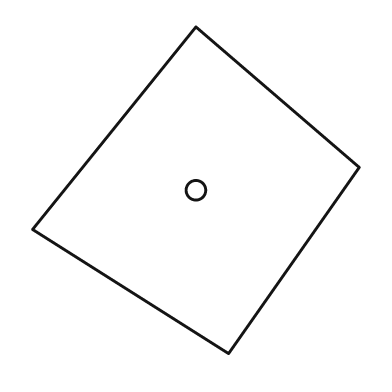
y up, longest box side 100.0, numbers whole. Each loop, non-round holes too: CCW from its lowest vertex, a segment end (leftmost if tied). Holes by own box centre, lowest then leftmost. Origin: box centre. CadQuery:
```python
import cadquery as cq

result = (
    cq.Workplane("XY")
    .moveTo(10.0, -50.0)
    .lineTo(50.0, 7.0)
    .lineTo(0.0, 50.0)
    .lineTo(-50.0, -12.0)
    .close()
    .moveTo(0.0, 0.0)
    .circle(3.0)
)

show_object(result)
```